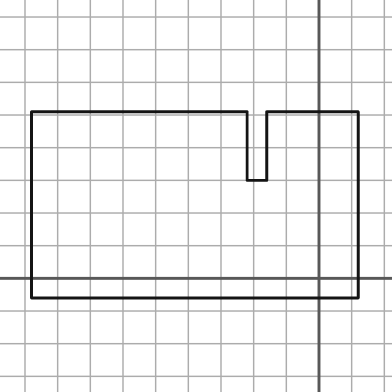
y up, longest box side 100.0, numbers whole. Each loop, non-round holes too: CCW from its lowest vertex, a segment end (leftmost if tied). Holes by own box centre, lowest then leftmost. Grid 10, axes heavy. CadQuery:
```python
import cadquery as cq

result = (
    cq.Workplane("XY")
    .moveTo(-88.0, -6.0)
    .lineTo(12.0, -6.0)
    .lineTo(12.0, 51.0)
    .lineTo(-16.0, 51.0)
    .lineTo(-16.0, 30.0)
    .lineTo(-22.0, 30.0)
    .lineTo(-22.0, 51.0)
    .lineTo(-88.0, 51.0)
    .close()
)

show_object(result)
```